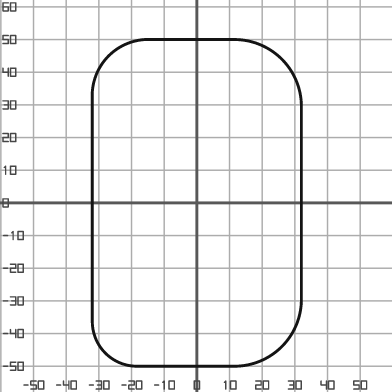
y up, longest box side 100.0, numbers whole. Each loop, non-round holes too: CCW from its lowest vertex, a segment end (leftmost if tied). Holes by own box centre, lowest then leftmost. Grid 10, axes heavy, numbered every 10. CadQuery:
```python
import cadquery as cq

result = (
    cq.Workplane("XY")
    .moveTo(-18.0, -50.0)
    .lineTo(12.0, -50.0)
    .threePointArc((26.0, -44.0), (32.0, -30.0))
    .lineTo(32.0, 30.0)
    .threePointArc((26.0, 44.0), (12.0, 50.0))
    .lineTo(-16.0, 50.0)
    .threePointArc((-27.0, 45.0), (-32.0, 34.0))
    .lineTo(-32.0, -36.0)
    .threePointArc((-28.0, -46.0), (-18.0, -50.0))
    .close()
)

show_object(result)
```